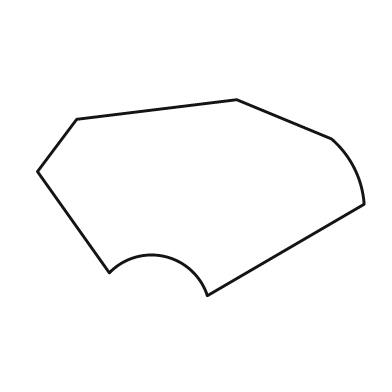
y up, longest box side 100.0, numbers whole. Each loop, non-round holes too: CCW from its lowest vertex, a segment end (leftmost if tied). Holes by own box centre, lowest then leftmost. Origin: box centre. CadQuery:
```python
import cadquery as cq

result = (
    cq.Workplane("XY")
    .moveTo(2.0, -30.0)
    .lineTo(50.0, -2.0)
    .threePointArc((47.0, 9.0), (40.0, 18.0))
    .lineTo(11.0, 30.0)
    .lineTo(-38.0, 24.0)
    .lineTo(-50.0, 8.0)
    .lineTo(-28.0, -23.0)
    .threePointArc((-11.0, -18.0), (2.0, -30.0))
    .close()
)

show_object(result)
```